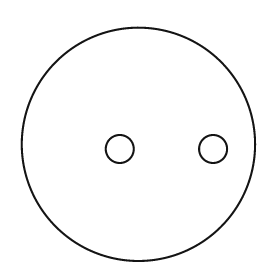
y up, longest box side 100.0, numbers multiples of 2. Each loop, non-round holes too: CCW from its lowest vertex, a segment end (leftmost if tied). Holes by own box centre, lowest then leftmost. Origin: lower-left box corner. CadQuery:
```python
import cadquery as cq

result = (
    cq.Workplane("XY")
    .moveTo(50.0, 50.0)
    .circle(50.0)
    .moveTo(42.0, 48.0)
    .circle(6.0)
    .moveTo(82.0, 48.0)
    .circle(6.0)
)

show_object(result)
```